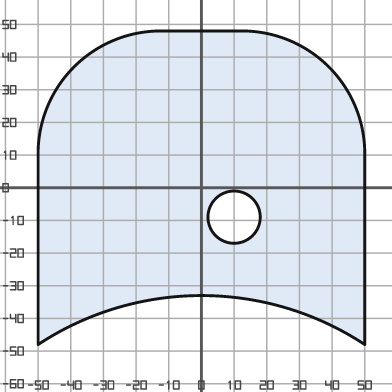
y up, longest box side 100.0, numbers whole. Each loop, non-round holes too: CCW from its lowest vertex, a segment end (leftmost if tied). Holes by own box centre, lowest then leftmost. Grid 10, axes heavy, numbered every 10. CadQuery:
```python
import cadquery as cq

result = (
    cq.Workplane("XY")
    .moveTo(-50.0, -48.0)
    .threePointArc((0.0, -33.0), (50.0, -48.0))
    .lineTo(50.0, 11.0)
    .threePointArc((39.0, 37.0), (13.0, 48.0))
    .lineTo(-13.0, 48.0)
    .threePointArc((-39.0, 37.0), (-50.0, 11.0))
    .close()
    .moveTo(10.0, -9.0)
    .circle(8.0)
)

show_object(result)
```